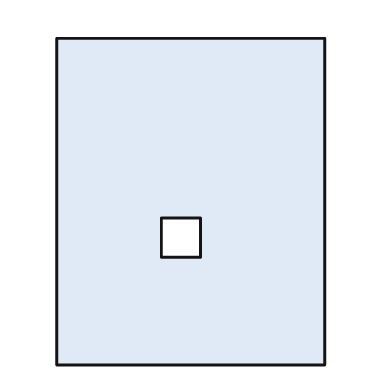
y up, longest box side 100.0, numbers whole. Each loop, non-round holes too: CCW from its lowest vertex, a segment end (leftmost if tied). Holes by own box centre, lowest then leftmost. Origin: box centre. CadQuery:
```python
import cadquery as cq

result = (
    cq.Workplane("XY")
    .moveTo(-41.0, -50.0)
    .lineTo(41.0, -50.0)
    .lineTo(41.0, 50.0)
    .lineTo(-41.0, 50.0)
    .close()
    .moveTo(-9.0, -17.0)
    .lineTo(3.0, -17.0)
    .lineTo(3.0, -5.0)
    .lineTo(-9.0, -5.0)
    .close()
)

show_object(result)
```